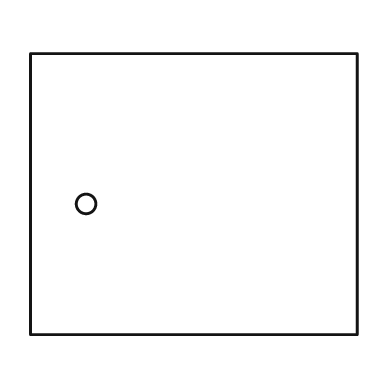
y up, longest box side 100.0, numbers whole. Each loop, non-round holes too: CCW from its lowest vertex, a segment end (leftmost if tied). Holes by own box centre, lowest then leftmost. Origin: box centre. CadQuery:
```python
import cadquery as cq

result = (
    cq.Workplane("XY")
    .moveTo(-50.0, -43.0)
    .lineTo(50.0, -43.0)
    .lineTo(50.0, 43.0)
    .lineTo(-50.0, 43.0)
    .close()
    .moveTo(-33.0, -3.0)
    .circle(3.0)
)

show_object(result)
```